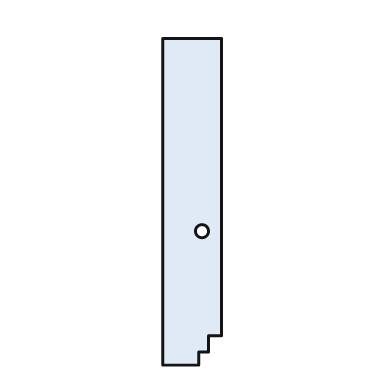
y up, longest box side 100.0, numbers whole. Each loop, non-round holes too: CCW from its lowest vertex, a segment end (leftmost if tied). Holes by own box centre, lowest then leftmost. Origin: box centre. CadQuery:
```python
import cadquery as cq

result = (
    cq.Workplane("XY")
    .moveTo(-9.0, -50.0)
    .lineTo(2.0, -50.0)
    .lineTo(2.0, -46.0)
    .lineTo(5.0, -46.0)
    .lineTo(5.0, -41.0)
    .lineTo(9.0, -41.0)
    .lineTo(9.0, 50.0)
    .lineTo(-9.0, 50.0)
    .close()
    .moveTo(3.0, -9.0)
    .circle(2.0)
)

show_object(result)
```